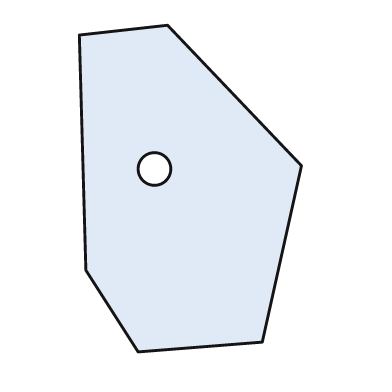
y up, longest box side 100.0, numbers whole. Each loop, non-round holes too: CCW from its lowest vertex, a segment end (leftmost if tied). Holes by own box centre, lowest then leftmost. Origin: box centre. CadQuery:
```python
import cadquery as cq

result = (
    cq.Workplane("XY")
    .moveTo(-16.0, -50.0)
    .lineTo(22.0, -47.0)
    .lineTo(34.0, 7.0)
    .lineTo(-7.0, 50.0)
    .lineTo(-34.0, 47.0)
    .lineTo(-32.0, -25.0)
    .close()
    .moveTo(-11.0, 6.0)
    .circle(5.0)
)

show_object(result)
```